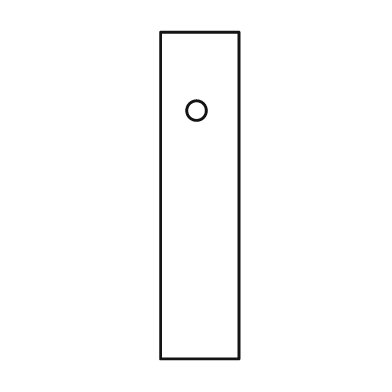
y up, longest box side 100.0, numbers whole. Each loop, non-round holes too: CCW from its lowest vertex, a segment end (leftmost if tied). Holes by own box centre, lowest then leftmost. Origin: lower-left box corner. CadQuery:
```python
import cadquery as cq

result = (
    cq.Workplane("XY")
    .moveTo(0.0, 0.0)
    .lineTo(24.0, 0.0)
    .lineTo(24.0, 100.0)
    .lineTo(0.0, 100.0)
    .close()
    .moveTo(11.0, 76.0)
    .circle(3.0)
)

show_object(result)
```